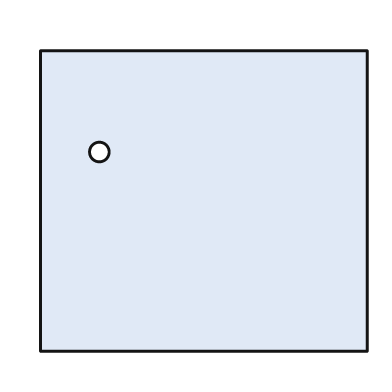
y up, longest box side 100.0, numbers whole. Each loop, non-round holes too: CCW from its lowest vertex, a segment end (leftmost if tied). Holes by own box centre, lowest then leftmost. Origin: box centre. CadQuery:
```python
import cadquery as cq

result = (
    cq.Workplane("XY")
    .moveTo(-50.0, -46.0)
    .lineTo(50.0, -46.0)
    .lineTo(50.0, 46.0)
    .lineTo(-50.0, 46.0)
    .close()
    .moveTo(-32.0, 15.0)
    .circle(3.0)
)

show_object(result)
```